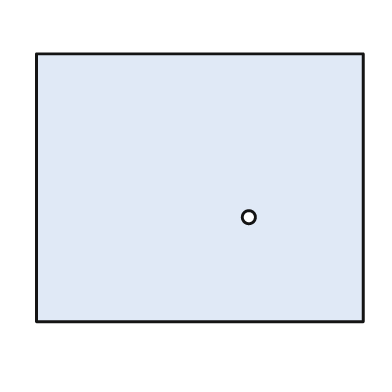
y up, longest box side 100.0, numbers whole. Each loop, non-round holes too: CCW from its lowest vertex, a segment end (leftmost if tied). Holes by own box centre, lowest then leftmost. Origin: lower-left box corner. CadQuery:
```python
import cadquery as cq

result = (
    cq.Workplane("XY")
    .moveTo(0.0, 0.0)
    .lineTo(100.0, 0.0)
    .lineTo(100.0, 82.0)
    .lineTo(0.0, 82.0)
    .close()
    .moveTo(65.0, 32.0)
    .circle(2.0)
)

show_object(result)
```